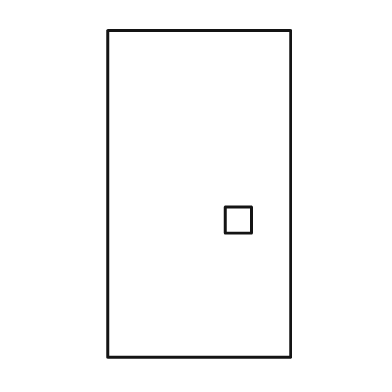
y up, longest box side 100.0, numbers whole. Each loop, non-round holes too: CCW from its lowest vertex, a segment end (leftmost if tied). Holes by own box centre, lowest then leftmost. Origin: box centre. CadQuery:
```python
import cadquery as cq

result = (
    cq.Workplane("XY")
    .moveTo(-28.0, -50.0)
    .lineTo(28.0, -50.0)
    .lineTo(28.0, 50.0)
    .lineTo(-28.0, 50.0)
    .close()
    .moveTo(8.0, -12.0)
    .lineTo(16.0, -12.0)
    .lineTo(16.0, -4.0)
    .lineTo(8.0, -4.0)
    .close()
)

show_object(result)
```